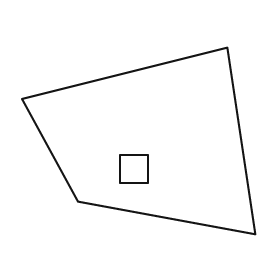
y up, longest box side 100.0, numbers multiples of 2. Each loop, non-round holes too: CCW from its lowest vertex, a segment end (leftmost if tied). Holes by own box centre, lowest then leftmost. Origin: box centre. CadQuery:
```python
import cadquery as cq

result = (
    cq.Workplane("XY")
    .moveTo(50.0, -40.0)
    .lineTo(38.0, 40.0)
    .lineTo(-50.0, 18.0)
    .lineTo(-26.0, -26.0)
    .close()
    .moveTo(-8.0, -18.0)
    .lineTo(4.0, -18.0)
    .lineTo(4.0, -6.0)
    .lineTo(-8.0, -6.0)
    .close()
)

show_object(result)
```